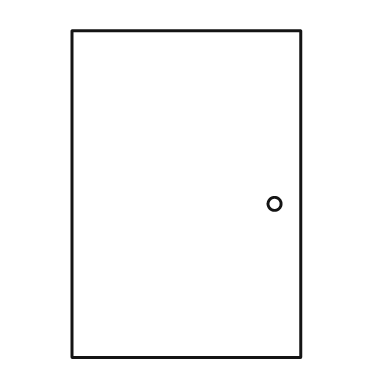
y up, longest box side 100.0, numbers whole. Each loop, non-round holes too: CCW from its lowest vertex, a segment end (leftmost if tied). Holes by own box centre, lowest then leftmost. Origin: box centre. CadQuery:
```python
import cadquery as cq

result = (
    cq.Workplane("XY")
    .moveTo(-35.0, -50.0)
    .lineTo(35.0, -50.0)
    .lineTo(35.0, 50.0)
    .lineTo(-35.0, 50.0)
    .close()
    .moveTo(27.0, -3.0)
    .circle(2.0)
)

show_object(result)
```